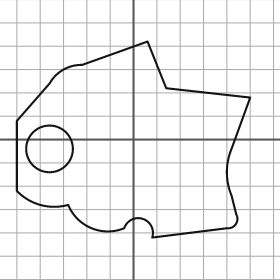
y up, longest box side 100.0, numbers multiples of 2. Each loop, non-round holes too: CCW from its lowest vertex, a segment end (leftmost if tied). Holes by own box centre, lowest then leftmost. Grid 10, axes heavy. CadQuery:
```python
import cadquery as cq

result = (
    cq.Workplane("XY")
    .moveTo(8.0, -42.0)
    .lineTo(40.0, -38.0)
    .threePointArc((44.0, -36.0), (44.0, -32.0))
    .lineTo(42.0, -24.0)
    .threePointArc((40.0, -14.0), (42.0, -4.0))
    .lineTo(50.0, 18.0)
    .lineTo(14.0, 22.0)
    .lineTo(6.0, 42.0)
    .lineTo(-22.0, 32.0)
    .threePointArc((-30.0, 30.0), (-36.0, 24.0))
    .lineTo(-50.0, 8.0)
    .lineTo(-50.0, -22.0)
    .threePointArc((-40.0, -28.0), (-28.0, -28.0))
    .threePointArc((-18.0, -38.0), (-4.0, -38.0))
    .threePointArc((4.0, -34.0), (8.0, -42.0))
    .close()
    .moveTo(-36.0, -4.0)
    .circle(10.0)
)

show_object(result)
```